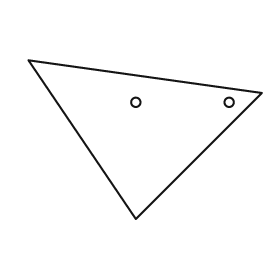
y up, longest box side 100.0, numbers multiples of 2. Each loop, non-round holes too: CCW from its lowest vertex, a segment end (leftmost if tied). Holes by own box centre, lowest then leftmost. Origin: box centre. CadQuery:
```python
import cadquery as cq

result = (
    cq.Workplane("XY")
    .moveTo(-4.0, -34.0)
    .lineTo(50.0, 20.0)
    .lineTo(-50.0, 34.0)
    .close()
    .moveTo(-4.0, 16.0)
    .circle(2.0)
    .moveTo(36.0, 16.0)
    .circle(2.0)
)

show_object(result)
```